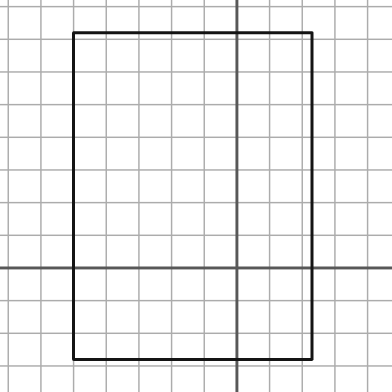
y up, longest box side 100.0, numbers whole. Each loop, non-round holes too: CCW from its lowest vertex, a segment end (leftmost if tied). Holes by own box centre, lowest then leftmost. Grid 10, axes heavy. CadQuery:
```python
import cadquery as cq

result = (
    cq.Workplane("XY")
    .moveTo(-50.0, -28.0)
    .lineTo(23.0, -28.0)
    .lineTo(23.0, 72.0)
    .lineTo(-50.0, 72.0)
    .close()
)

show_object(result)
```